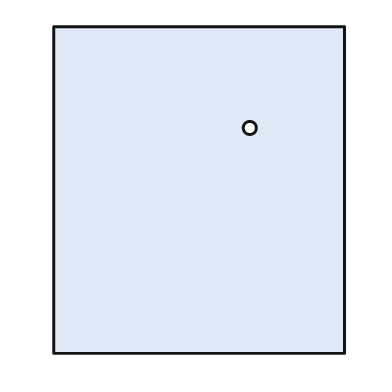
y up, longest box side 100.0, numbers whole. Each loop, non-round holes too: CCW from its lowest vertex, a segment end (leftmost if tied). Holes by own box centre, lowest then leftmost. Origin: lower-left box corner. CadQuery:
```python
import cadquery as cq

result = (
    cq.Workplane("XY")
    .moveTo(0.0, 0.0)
    .lineTo(89.0, 0.0)
    .lineTo(89.0, 100.0)
    .lineTo(0.0, 100.0)
    .close()
    .moveTo(60.0, 69.0)
    .circle(2.0)
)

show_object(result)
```